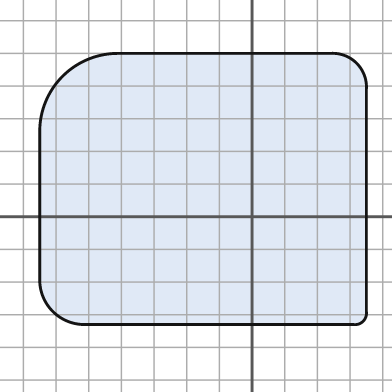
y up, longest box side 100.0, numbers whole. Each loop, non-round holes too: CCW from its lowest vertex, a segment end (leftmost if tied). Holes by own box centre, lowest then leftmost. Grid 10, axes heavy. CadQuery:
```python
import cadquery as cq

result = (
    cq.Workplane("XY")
    .moveTo(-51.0, -33.0)
    .lineTo(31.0, -33.0)
    .threePointArc((34.0, -32.0), (35.0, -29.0))
    .lineTo(35.0, 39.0)
    .threePointArc((32.0, 47.0), (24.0, 50.0))
    .lineTo(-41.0, 50.0)
    .threePointArc((-58.0, 43.0), (-65.0, 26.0))
    .lineTo(-65.0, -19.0)
    .threePointArc((-61.0, -29.0), (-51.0, -33.0))
    .close()
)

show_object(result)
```